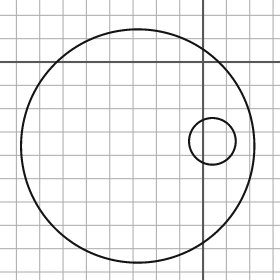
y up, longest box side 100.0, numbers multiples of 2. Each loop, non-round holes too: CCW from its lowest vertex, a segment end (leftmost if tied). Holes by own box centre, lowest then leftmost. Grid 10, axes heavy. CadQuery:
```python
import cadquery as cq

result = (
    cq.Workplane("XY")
    .moveTo(-28.0, -36.0)
    .circle(50.0)
    .moveTo(4.0, -34.0)
    .circle(10.0)
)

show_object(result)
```